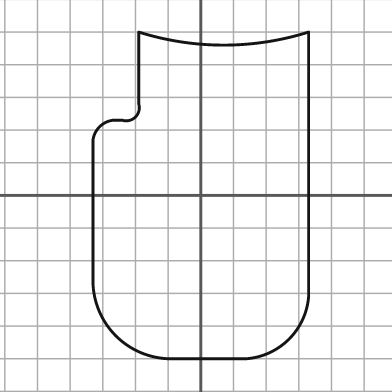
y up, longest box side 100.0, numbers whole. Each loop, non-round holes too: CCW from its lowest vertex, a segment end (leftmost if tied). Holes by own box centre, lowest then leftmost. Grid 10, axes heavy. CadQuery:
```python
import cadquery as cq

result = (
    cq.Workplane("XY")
    .moveTo(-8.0, -50.0)
    .lineTo(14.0, -50.0)
    .threePointArc((27.0, -44.0), (33.0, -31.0))
    .lineTo(33.0, 50.0)
    .threePointArc((7.0, 46.0), (-19.0, 50.0))
    .lineTo(-19.0, 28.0)
    .threePointArc((-20.0, 24.0), (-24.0, 23.0))
    .lineTo(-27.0, 23.0)
    .threePointArc((-31.0, 21.0), (-33.0, 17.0))
    .lineTo(-33.0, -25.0)
    .threePointArc((-26.0, -43.0), (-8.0, -50.0))
    .close()
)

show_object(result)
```